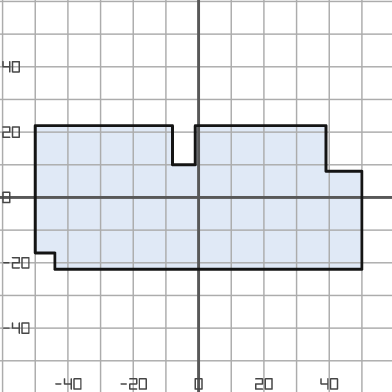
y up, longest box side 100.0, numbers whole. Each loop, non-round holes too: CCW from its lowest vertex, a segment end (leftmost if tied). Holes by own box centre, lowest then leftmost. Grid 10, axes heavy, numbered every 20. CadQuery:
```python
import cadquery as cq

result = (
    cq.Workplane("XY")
    .moveTo(-44.0, -22.0)
    .lineTo(50.0, -22.0)
    .lineTo(50.0, 8.0)
    .lineTo(39.0, 8.0)
    .lineTo(39.0, 22.0)
    .lineTo(-1.0, 22.0)
    .lineTo(-1.0, 10.0)
    .lineTo(-8.0, 10.0)
    .lineTo(-8.0, 22.0)
    .lineTo(-50.0, 22.0)
    .lineTo(-50.0, -17.0)
    .lineTo(-44.0, -17.0)
    .close()
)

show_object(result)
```